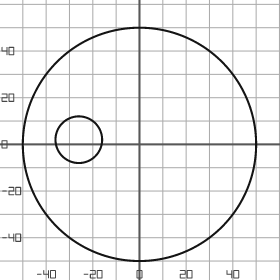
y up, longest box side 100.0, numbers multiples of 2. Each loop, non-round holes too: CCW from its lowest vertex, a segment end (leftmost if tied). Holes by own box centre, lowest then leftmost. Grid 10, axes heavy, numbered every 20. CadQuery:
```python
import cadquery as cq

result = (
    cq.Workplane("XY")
    .moveTo(0.0, 0.0)
    .circle(50.0)
    .moveTo(-26.0, 2.0)
    .circle(10.0)
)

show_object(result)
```